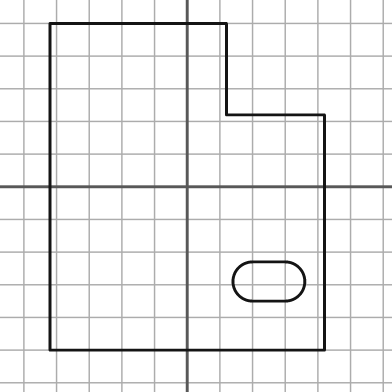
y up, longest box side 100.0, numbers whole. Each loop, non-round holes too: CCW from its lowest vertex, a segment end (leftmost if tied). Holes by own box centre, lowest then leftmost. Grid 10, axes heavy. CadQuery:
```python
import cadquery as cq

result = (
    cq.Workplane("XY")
    .moveTo(-42.0, -50.0)
    .lineTo(42.0, -50.0)
    .lineTo(42.0, 22.0)
    .lineTo(12.0, 22.0)
    .lineTo(12.0, 50.0)
    .lineTo(-42.0, 50.0)
    .close()
    .moveTo(20.0, -35.0)
    .lineTo(30.0, -35.0)
    .threePointArc((36.0, -29.0), (30.0, -23.0))
    .lineTo(20.0, -23.0)
    .threePointArc((14.0, -29.0), (20.0, -35.0))
    .close()
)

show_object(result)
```